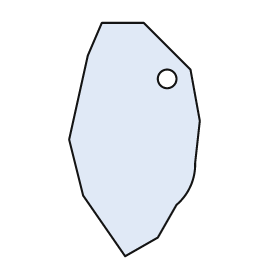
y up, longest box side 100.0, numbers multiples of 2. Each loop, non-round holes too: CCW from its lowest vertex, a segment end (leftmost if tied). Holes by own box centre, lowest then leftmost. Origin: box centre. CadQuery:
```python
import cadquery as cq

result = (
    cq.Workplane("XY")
    .moveTo(-4.0, -50.0)
    .lineTo(10.0, -42.0)
    .lineTo(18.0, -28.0)
    .threePointArc((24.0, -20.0), (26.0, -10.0))
    .lineTo(28.0, 8.0)
    .lineTo(24.0, 30.0)
    .lineTo(4.0, 50.0)
    .lineTo(-14.0, 50.0)
    .lineTo(-20.0, 36.0)
    .lineTo(-28.0, 0.0)
    .lineTo(-22.0, -24.0)
    .close()
    .moveTo(14.0, 26.0)
    .circle(4.0)
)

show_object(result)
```